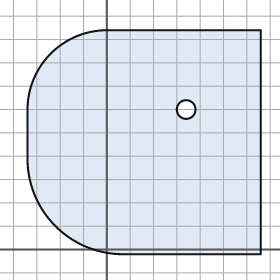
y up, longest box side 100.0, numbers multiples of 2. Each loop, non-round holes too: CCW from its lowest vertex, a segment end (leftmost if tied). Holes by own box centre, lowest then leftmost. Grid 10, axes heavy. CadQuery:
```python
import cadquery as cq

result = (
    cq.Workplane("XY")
    .moveTo(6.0, -2.0)
    .lineTo(66.0, -2.0)
    .lineTo(66.0, 94.0)
    .lineTo(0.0, 94.0)
    .threePointArc((-24.0, 84.0), (-34.0, 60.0))
    .lineTo(-34.0, 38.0)
    .threePointArc((-22.0, 10.0), (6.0, -2.0))
    .close()
    .moveTo(34.0, 60.0)
    .circle(4.0)
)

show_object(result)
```